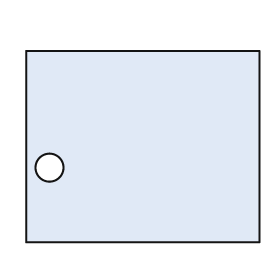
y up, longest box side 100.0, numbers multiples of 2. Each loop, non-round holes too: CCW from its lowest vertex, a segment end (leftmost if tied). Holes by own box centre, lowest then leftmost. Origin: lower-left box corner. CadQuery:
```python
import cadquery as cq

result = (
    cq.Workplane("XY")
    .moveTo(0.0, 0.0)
    .lineTo(100.0, 0.0)
    .lineTo(100.0, 82.0)
    .lineTo(0.0, 82.0)
    .close()
    .moveTo(10.0, 32.0)
    .circle(6.0)
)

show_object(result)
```